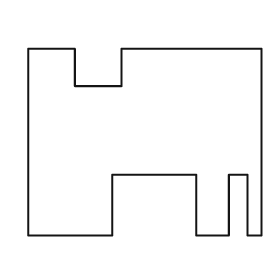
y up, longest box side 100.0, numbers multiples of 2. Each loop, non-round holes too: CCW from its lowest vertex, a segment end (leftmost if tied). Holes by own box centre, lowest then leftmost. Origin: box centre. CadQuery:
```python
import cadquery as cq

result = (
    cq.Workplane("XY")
    .moveTo(-50.0, -40.0)
    .lineTo(-14.0, -40.0)
    .lineTo(-14.0, -14.0)
    .lineTo(22.0, -14.0)
    .lineTo(22.0, -40.0)
    .lineTo(36.0, -40.0)
    .lineTo(36.0, -14.0)
    .lineTo(44.0, -14.0)
    .lineTo(44.0, -40.0)
    .lineTo(50.0, -40.0)
    .lineTo(50.0, 40.0)
    .lineTo(-10.0, 40.0)
    .lineTo(-10.0, 24.0)
    .lineTo(-30.0, 24.0)
    .lineTo(-30.0, 40.0)
    .lineTo(-50.0, 40.0)
    .close()
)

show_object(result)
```